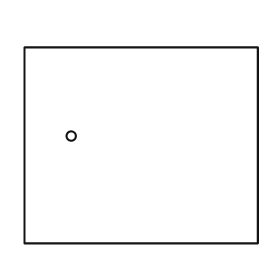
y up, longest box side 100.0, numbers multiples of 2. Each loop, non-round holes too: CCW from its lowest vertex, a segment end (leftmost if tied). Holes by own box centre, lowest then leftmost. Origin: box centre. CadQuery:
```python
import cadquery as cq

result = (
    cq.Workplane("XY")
    .moveTo(-50.0, -42.0)
    .lineTo(50.0, -42.0)
    .lineTo(50.0, 42.0)
    .lineTo(-50.0, 42.0)
    .close()
    .moveTo(-30.0, 4.0)
    .circle(2.0)
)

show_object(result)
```